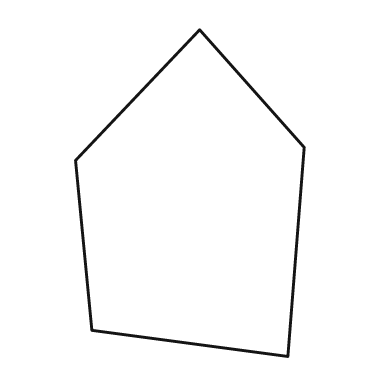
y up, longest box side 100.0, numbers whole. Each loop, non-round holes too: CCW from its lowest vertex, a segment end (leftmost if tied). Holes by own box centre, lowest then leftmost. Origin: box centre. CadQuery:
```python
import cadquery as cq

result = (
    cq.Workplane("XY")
    .moveTo(30.0, -50.0)
    .lineTo(35.0, 14.0)
    .lineTo(3.0, 50.0)
    .lineTo(-35.0, 10.0)
    .lineTo(-30.0, -42.0)
    .close()
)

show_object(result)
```